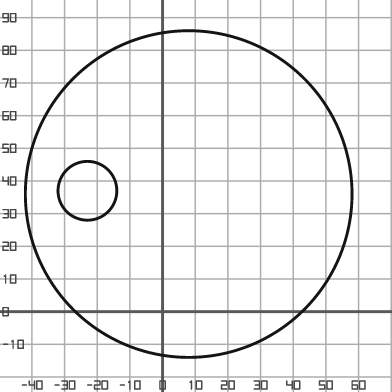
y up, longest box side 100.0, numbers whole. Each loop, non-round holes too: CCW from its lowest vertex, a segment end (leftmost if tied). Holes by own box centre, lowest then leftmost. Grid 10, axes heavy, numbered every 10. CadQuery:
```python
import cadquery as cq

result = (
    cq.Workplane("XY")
    .moveTo(8.0, 36.0)
    .circle(50.0)
    .moveTo(-23.0, 37.0)
    .circle(9.0)
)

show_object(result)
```